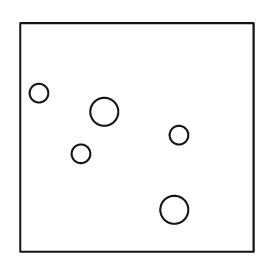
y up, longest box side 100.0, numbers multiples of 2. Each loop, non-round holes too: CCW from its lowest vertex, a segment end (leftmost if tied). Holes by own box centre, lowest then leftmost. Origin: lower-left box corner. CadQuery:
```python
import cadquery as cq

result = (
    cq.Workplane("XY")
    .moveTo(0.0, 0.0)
    .lineTo(100.0, 0.0)
    .lineTo(100.0, 98.0)
    .lineTo(0.0, 98.0)
    .close()
    .moveTo(66.0, 18.0)
    .circle(6.0)
    .moveTo(26.0, 42.0)
    .circle(4.0)
    .moveTo(68.0, 50.0)
    .circle(4.0)
    .moveTo(36.0, 60.0)
    .circle(6.0)
    .moveTo(8.0, 68.0)
    .circle(4.0)
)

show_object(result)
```